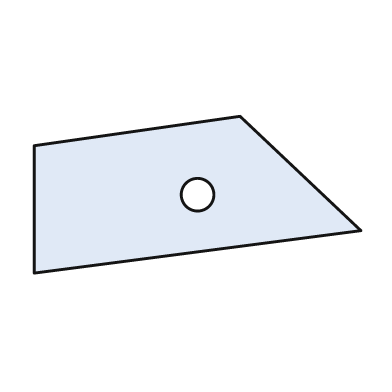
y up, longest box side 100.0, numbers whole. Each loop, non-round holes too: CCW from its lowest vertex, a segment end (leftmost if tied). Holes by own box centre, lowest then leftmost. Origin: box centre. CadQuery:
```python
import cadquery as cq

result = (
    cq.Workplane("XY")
    .moveTo(-50.0, -24.0)
    .lineTo(50.0, -11.0)
    .lineTo(13.0, 24.0)
    .lineTo(-50.0, 15.0)
    .close()
    .moveTo(0.0, 0.0)
    .circle(5.0)
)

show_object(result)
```